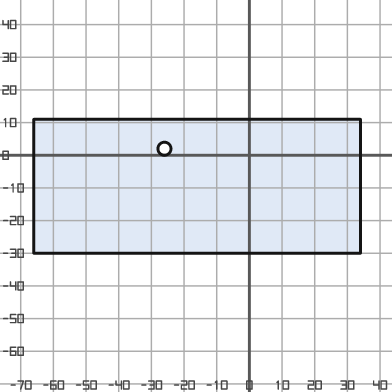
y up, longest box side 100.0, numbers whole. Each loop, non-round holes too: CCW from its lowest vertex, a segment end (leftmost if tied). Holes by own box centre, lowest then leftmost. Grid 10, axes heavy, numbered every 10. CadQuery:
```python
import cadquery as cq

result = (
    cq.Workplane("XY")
    .moveTo(-66.0, -30.0)
    .lineTo(34.0, -30.0)
    .lineTo(34.0, 11.0)
    .lineTo(-66.0, 11.0)
    .close()
    .moveTo(-26.0, 2.0)
    .circle(2.0)
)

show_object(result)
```